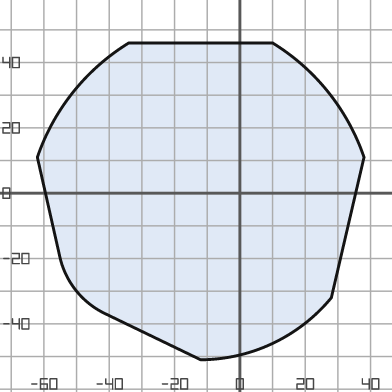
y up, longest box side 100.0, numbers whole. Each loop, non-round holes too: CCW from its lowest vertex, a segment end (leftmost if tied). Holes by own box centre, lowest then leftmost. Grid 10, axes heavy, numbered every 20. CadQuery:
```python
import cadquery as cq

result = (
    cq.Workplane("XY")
    .moveTo(-12.0, -51.0)
    .threePointArc((10.0, -46.0), (28.0, -32.0))
    .lineTo(38.0, 11.0)
    .threePointArc((27.0, 31.0), (10.0, 46.0))
    .lineTo(-34.0, 46.0)
    .threePointArc((-51.0, 31.0), (-62.0, 11.0))
    .lineTo(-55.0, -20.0)
    .threePointArc((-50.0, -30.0), (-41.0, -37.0))
    .close()
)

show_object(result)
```